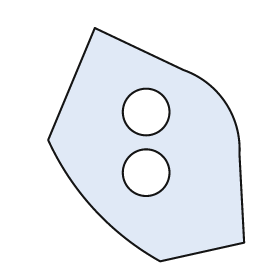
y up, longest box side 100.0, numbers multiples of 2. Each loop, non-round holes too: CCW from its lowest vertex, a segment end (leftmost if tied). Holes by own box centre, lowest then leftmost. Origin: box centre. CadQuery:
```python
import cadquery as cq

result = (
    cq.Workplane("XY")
    .moveTo(6.0, -50.0)
    .lineTo(42.0, -42.0)
    .lineTo(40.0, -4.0)
    .threePointArc((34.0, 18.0), (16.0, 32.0))
    .lineTo(-22.0, 50.0)
    .lineTo(-42.0, 2.0)
    .threePointArc((-22.0, -28.0), (6.0, -50.0))
    .close()
    .moveTo(0.0, -12.0)
    .circle(10.0)
    .moveTo(0.0, 14.0)
    .circle(10.0)
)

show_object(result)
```